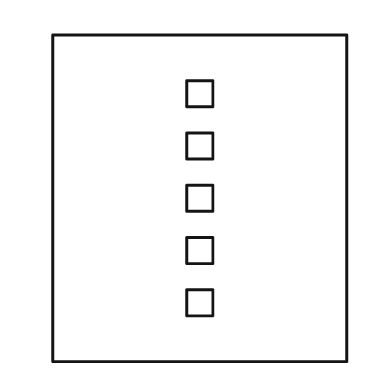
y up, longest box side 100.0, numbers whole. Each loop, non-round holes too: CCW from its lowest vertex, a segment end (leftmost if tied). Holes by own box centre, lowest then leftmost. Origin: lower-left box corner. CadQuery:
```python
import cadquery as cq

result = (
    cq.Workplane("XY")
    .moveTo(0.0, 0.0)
    .lineTo(90.0, 0.0)
    .lineTo(90.0, 100.0)
    .lineTo(0.0, 100.0)
    .close()
    .moveTo(41.0, 14.0)
    .lineTo(49.0, 14.0)
    .lineTo(49.0, 22.0)
    .lineTo(41.0, 22.0)
    .close()
    .moveTo(41.0, 30.0)
    .lineTo(49.0, 30.0)
    .lineTo(49.0, 38.0)
    .lineTo(41.0, 38.0)
    .close()
    .moveTo(41.0, 46.0)
    .lineTo(49.0, 46.0)
    .lineTo(49.0, 54.0)
    .lineTo(41.0, 54.0)
    .close()
    .moveTo(41.0, 62.0)
    .lineTo(49.0, 62.0)
    .lineTo(49.0, 70.0)
    .lineTo(41.0, 70.0)
    .close()
    .moveTo(41.0, 78.0)
    .lineTo(49.0, 78.0)
    .lineTo(49.0, 86.0)
    .lineTo(41.0, 86.0)
    .close()
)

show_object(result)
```